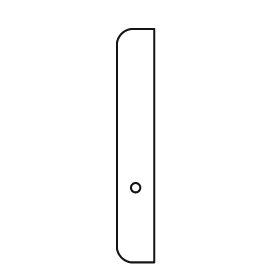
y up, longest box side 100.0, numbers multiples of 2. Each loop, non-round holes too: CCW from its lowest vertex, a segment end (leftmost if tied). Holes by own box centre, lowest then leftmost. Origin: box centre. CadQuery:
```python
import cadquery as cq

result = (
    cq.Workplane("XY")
    .moveTo(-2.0, -50.0)
    .lineTo(8.0, -50.0)
    .lineTo(8.0, 50.0)
    .lineTo(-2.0, 50.0)
    .threePointArc((-6.0, 48.0), (-8.0, 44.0))
    .lineTo(-8.0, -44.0)
    .threePointArc((-6.0, -48.0), (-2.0, -50.0))
    .close()
    .moveTo(0.0, -18.0)
    .circle(2.0)
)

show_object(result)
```